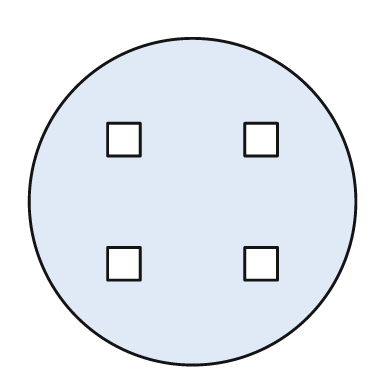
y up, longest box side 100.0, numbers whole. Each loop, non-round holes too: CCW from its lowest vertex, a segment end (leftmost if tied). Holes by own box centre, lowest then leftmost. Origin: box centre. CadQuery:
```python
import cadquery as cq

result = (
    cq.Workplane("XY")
    .moveTo(0.0, 0.0)
    .circle(50.0)
    .moveTo(-26.0, -24.0)
    .lineTo(-16.0, -24.0)
    .lineTo(-16.0, -14.0)
    .lineTo(-26.0, -14.0)
    .close()
    .moveTo(16.0, -24.0)
    .lineTo(26.0, -24.0)
    .lineTo(26.0, -14.0)
    .lineTo(16.0, -14.0)
    .close()
    .moveTo(-26.0, 14.0)
    .lineTo(-16.0, 14.0)
    .lineTo(-16.0, 24.0)
    .lineTo(-26.0, 24.0)
    .close()
    .moveTo(16.0, 14.0)
    .lineTo(26.0, 14.0)
    .lineTo(26.0, 24.0)
    .lineTo(16.0, 24.0)
    .close()
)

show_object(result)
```